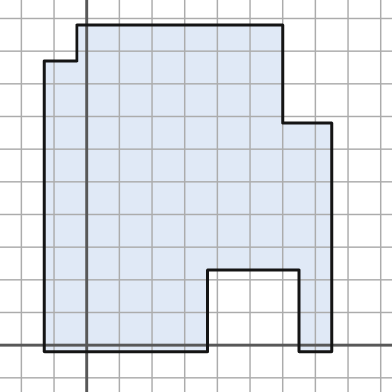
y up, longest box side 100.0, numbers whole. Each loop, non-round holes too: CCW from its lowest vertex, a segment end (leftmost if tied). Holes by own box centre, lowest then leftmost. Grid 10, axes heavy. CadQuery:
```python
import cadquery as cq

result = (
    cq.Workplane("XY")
    .moveTo(-13.0, -2.0)
    .lineTo(37.0, -2.0)
    .lineTo(37.0, 23.0)
    .lineTo(65.0, 23.0)
    .lineTo(65.0, -2.0)
    .lineTo(75.0, -2.0)
    .lineTo(75.0, 68.0)
    .lineTo(60.0, 68.0)
    .lineTo(60.0, 98.0)
    .lineTo(-3.0, 98.0)
    .lineTo(-3.0, 87.0)
    .lineTo(-13.0, 87.0)
    .close()
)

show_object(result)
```